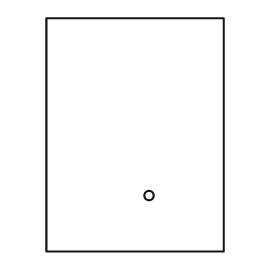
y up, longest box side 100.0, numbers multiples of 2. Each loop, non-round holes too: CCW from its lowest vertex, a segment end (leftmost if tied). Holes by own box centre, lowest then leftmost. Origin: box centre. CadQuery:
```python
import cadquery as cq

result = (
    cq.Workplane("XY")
    .moveTo(-38.0, -50.0)
    .lineTo(38.0, -50.0)
    .lineTo(38.0, 50.0)
    .lineTo(-38.0, 50.0)
    .close()
    .moveTo(6.0, -26.0)
    .circle(2.0)
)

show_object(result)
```